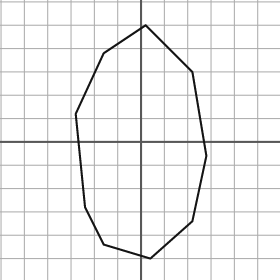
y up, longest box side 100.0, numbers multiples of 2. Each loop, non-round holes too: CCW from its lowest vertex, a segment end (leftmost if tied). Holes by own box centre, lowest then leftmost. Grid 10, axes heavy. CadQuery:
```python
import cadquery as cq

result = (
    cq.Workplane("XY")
    .moveTo(4.0, -50.0)
    .lineTo(22.0, -34.0)
    .lineTo(28.0, -6.0)
    .lineTo(22.0, 30.0)
    .lineTo(2.0, 50.0)
    .lineTo(-16.0, 38.0)
    .lineTo(-28.0, 12.0)
    .lineTo(-24.0, -28.0)
    .lineTo(-16.0, -44.0)
    .close()
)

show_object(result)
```